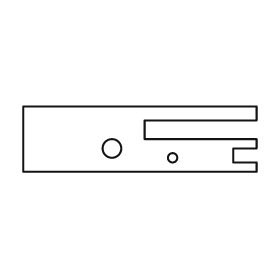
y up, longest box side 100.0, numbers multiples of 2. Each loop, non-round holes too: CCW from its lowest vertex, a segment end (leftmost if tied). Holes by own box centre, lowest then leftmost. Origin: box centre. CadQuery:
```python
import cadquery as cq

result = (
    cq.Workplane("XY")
    .moveTo(-50.0, -14.0)
    .lineTo(50.0, -14.0)
    .lineTo(50.0, -10.0)
    .lineTo(40.0, -10.0)
    .lineTo(40.0, -4.0)
    .lineTo(50.0, -4.0)
    .lineTo(50.0, 0.0)
    .lineTo(2.0, 0.0)
    .lineTo(2.0, 8.0)
    .lineTo(50.0, 8.0)
    .lineTo(50.0, 14.0)
    .lineTo(-50.0, 14.0)
    .close()
    .moveTo(14.0, -8.0)
    .circle(2.0)
    .moveTo(-12.0, -4.0)
    .circle(4.0)
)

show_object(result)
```